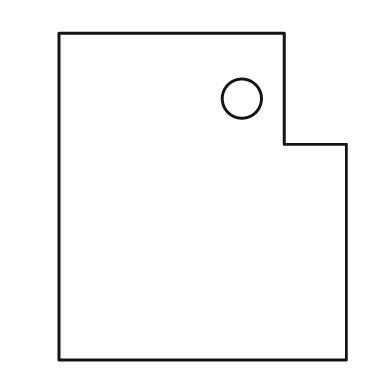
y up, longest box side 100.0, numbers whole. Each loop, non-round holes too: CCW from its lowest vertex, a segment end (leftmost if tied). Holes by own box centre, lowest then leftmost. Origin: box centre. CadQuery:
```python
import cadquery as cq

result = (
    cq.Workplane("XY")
    .moveTo(-44.0, -50.0)
    .lineTo(44.0, -50.0)
    .lineTo(44.0, 16.0)
    .lineTo(25.0, 16.0)
    .lineTo(25.0, 50.0)
    .lineTo(-44.0, 50.0)
    .close()
    .moveTo(12.0, 30.0)
    .circle(6.0)
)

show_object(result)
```